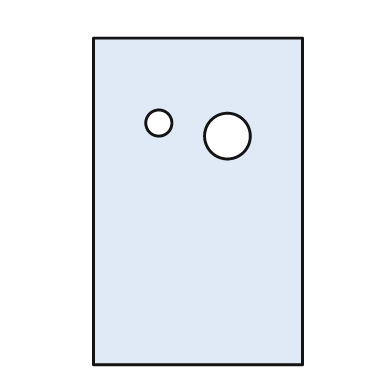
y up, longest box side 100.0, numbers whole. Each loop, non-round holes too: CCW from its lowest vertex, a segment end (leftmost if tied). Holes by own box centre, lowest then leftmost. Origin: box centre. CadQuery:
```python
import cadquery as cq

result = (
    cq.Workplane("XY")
    .moveTo(-32.0, -50.0)
    .lineTo(32.0, -50.0)
    .lineTo(32.0, 50.0)
    .lineTo(-32.0, 50.0)
    .close()
    .moveTo(9.0, 20.0)
    .circle(7.0)
    .moveTo(-12.0, 24.0)
    .circle(4.0)
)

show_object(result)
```